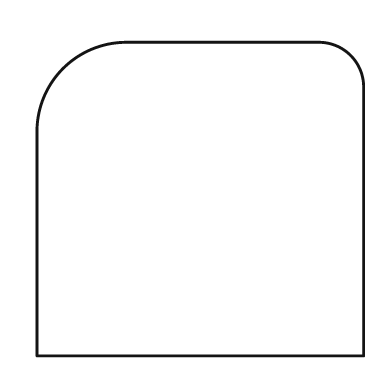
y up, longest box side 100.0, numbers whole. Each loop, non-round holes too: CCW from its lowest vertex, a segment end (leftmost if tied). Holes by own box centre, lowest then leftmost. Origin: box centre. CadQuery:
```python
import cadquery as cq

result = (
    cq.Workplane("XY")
    .moveTo(-50.0, -48.0)
    .lineTo(50.0, -48.0)
    .lineTo(50.0, 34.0)
    .threePointArc((46.0, 44.0), (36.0, 48.0))
    .lineTo(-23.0, 48.0)
    .threePointArc((-42.0, 40.0), (-50.0, 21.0))
    .close()
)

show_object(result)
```